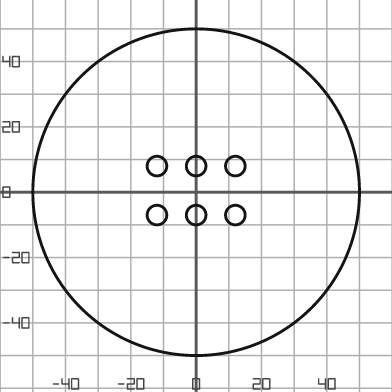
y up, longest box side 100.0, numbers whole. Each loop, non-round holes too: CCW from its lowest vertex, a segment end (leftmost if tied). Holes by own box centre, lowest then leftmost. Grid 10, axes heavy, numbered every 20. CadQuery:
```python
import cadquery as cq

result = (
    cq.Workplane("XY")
    .moveTo(0.0, 0.0)
    .circle(50.0)
    .moveTo(-12.0, -7.0)
    .circle(3.0)
    .moveTo(0.0, -7.0)
    .circle(3.0)
    .moveTo(12.0, -7.0)
    .circle(3.0)
    .moveTo(-12.0, 8.0)
    .circle(3.0)
    .moveTo(0.0, 8.0)
    .circle(3.0)
    .moveTo(12.0, 8.0)
    .circle(3.0)
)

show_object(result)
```